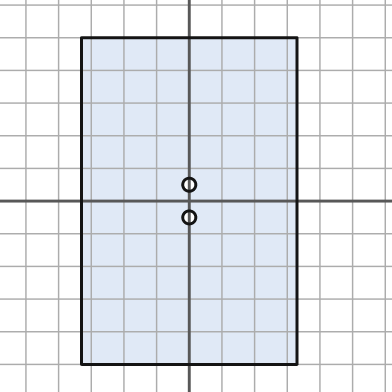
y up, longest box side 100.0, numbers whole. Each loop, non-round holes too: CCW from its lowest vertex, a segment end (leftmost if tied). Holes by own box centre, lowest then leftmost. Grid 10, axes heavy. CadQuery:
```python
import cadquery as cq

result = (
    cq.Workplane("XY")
    .moveTo(-33.0, -50.0)
    .lineTo(33.0, -50.0)
    .lineTo(33.0, 50.0)
    .lineTo(-33.0, 50.0)
    .close()
    .moveTo(0.0, -5.0)
    .circle(2.0)
    .moveTo(0.0, 5.0)
    .circle(2.0)
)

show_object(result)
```